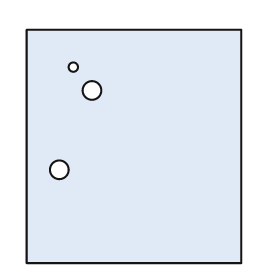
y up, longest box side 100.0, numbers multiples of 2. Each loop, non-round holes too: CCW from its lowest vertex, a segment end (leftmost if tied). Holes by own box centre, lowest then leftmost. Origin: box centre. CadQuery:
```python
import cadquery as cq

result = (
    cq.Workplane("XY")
    .moveTo(-46.0, -50.0)
    .lineTo(46.0, -50.0)
    .lineTo(46.0, 50.0)
    .lineTo(-46.0, 50.0)
    .close()
    .moveTo(-32.0, -10.0)
    .circle(4.0)
    .moveTo(-18.0, 24.0)
    .circle(4.0)
    .moveTo(-26.0, 34.0)
    .circle(2.0)
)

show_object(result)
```